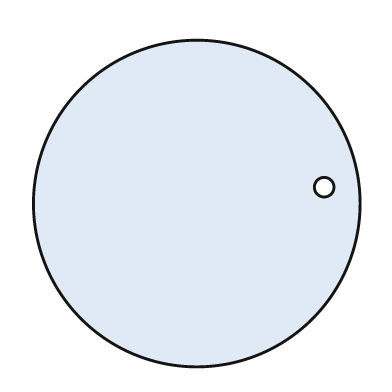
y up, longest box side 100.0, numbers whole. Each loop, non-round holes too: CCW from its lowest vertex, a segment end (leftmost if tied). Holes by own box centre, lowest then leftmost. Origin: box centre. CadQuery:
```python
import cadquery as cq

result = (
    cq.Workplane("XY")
    .moveTo(0.0, 0.0)
    .circle(50.0)
    .moveTo(39.0, 5.0)
    .circle(3.0)
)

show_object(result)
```